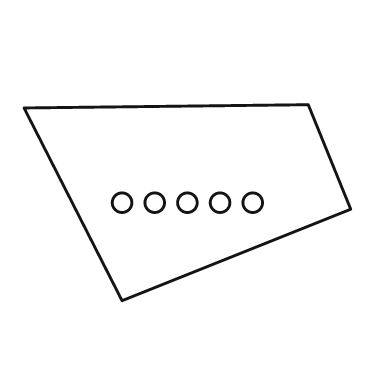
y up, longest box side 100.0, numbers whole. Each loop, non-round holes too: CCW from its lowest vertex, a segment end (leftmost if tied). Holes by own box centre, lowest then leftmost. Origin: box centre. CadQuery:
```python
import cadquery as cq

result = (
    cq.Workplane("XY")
    .moveTo(-20.0, -30.0)
    .lineTo(50.0, -2.0)
    .lineTo(37.0, 30.0)
    .lineTo(-50.0, 29.0)
    .close()
    .moveTo(-20.0, 0.0)
    .circle(3.0)
    .moveTo(-10.0, 0.0)
    .circle(3.0)
    .moveTo(0.0, 0.0)
    .circle(3.0)
    .moveTo(10.0, 0.0)
    .circle(3.0)
    .moveTo(20.0, 0.0)
    .circle(3.0)
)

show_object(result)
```